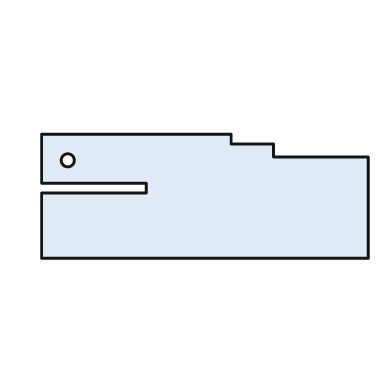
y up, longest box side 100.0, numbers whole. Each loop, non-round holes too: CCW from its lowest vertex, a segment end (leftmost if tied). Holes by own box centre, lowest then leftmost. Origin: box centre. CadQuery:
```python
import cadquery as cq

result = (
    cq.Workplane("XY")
    .moveTo(-50.0, -19.0)
    .lineTo(50.0, -19.0)
    .lineTo(50.0, 12.0)
    .lineTo(21.0, 12.0)
    .lineTo(21.0, 16.0)
    .lineTo(8.0, 16.0)
    .lineTo(8.0, 19.0)
    .lineTo(-50.0, 19.0)
    .lineTo(-50.0, 4.0)
    .lineTo(-18.0, 4.0)
    .lineTo(-18.0, 1.0)
    .lineTo(-50.0, 1.0)
    .close()
    .moveTo(-42.0, 11.0)
    .circle(2.0)
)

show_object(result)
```